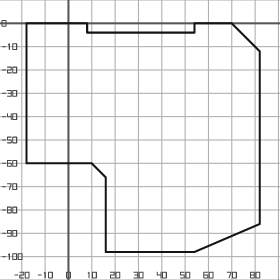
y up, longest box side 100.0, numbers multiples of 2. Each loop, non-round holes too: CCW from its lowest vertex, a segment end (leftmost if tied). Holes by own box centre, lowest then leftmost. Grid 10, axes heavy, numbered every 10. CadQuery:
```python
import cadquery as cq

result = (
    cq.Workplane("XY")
    .moveTo(16.0, -98.0)
    .lineTo(54.0, -98.0)
    .lineTo(82.0, -86.0)
    .lineTo(82.0, -12.0)
    .lineTo(70.0, 0.0)
    .lineTo(54.0, 0.0)
    .lineTo(54.0, -4.0)
    .lineTo(8.0, -4.0)
    .lineTo(8.0, 0.0)
    .lineTo(-18.0, 0.0)
    .lineTo(-18.0, -60.0)
    .lineTo(10.0, -60.0)
    .lineTo(16.0, -66.0)
    .close()
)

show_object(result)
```